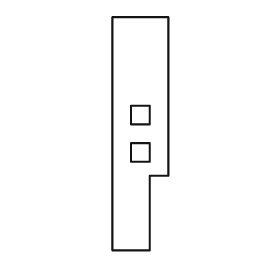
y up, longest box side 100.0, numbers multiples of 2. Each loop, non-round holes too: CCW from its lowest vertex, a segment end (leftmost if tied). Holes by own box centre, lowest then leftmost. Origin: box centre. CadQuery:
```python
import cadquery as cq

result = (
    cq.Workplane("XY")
    .moveTo(-12.0, -50.0)
    .lineTo(4.0, -50.0)
    .lineTo(4.0, -18.0)
    .lineTo(12.0, -18.0)
    .lineTo(12.0, 50.0)
    .lineTo(-12.0, 50.0)
    .close()
    .moveTo(-4.0, -12.0)
    .lineTo(4.0, -12.0)
    .lineTo(4.0, -4.0)
    .lineTo(-4.0, -4.0)
    .close()
    .moveTo(-4.0, 4.0)
    .lineTo(4.0, 4.0)
    .lineTo(4.0, 12.0)
    .lineTo(-4.0, 12.0)
    .close()
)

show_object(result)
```